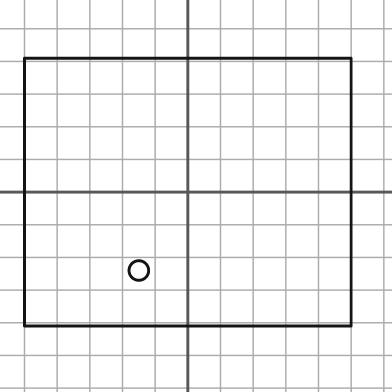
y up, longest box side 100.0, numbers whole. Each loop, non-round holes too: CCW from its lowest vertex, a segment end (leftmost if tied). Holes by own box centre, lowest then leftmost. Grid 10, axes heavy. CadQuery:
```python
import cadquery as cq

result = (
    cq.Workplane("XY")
    .moveTo(-50.0, -41.0)
    .lineTo(50.0, -41.0)
    .lineTo(50.0, 41.0)
    .lineTo(-50.0, 41.0)
    .close()
    .moveTo(-15.0, -24.0)
    .circle(3.0)
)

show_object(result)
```